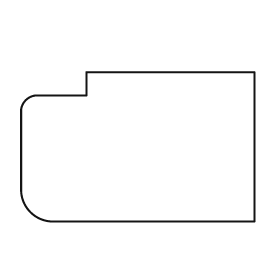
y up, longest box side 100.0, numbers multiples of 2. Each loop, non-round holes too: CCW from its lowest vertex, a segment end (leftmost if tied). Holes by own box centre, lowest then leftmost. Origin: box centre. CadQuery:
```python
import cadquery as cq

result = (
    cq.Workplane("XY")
    .moveTo(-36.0, -32.0)
    .lineTo(50.0, -32.0)
    .lineTo(50.0, 32.0)
    .lineTo(-22.0, 32.0)
    .lineTo(-22.0, 22.0)
    .lineTo(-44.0, 22.0)
    .threePointArc((-48.0, 20.0), (-50.0, 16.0))
    .lineTo(-50.0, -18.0)
    .threePointArc((-46.0, -28.0), (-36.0, -32.0))
    .close()
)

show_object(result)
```